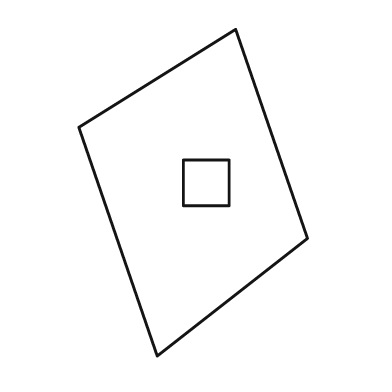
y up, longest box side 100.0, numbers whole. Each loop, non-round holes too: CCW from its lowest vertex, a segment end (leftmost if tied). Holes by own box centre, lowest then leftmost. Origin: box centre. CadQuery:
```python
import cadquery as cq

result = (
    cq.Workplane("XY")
    .moveTo(-11.0, -50.0)
    .lineTo(35.0, -14.0)
    .lineTo(13.0, 50.0)
    .lineTo(-35.0, 20.0)
    .close()
    .moveTo(-3.0, -4.0)
    .lineTo(11.0, -4.0)
    .lineTo(11.0, 10.0)
    .lineTo(-3.0, 10.0)
    .close()
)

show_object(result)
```